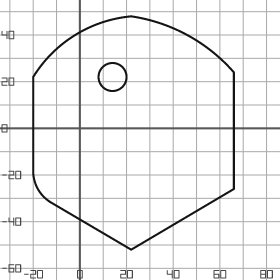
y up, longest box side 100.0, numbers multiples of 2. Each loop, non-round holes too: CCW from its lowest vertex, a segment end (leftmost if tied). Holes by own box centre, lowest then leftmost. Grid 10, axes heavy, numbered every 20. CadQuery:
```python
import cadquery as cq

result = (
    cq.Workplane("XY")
    .moveTo(22.0, -52.0)
    .lineTo(66.0, -26.0)
    .lineTo(66.0, 24.0)
    .threePointArc((46.0, 40.0), (22.0, 48.0))
    .threePointArc((-2.0, 40.0), (-20.0, 22.0))
    .lineTo(-20.0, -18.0)
    .threePointArc((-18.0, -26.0), (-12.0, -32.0))
    .close()
    .moveTo(14.0, 22.0)
    .circle(6.0)
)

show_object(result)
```